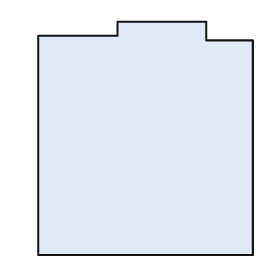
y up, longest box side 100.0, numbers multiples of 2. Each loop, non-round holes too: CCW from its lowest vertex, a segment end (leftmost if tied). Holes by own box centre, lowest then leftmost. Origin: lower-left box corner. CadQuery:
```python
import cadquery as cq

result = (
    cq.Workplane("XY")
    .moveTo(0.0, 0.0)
    .lineTo(92.0, 0.0)
    .lineTo(92.0, 92.0)
    .lineTo(72.0, 92.0)
    .lineTo(72.0, 100.0)
    .lineTo(34.0, 100.0)
    .lineTo(34.0, 94.0)
    .lineTo(0.0, 94.0)
    .close()
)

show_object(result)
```